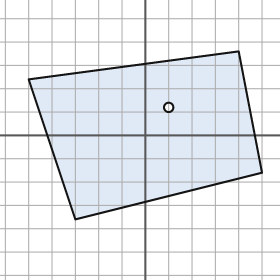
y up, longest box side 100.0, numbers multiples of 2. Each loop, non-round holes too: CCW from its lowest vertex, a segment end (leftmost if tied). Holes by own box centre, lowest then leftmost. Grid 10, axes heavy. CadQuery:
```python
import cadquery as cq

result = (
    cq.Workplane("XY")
    .moveTo(-30.0, -36.0)
    .lineTo(50.0, -16.0)
    .lineTo(40.0, 36.0)
    .lineTo(-50.0, 24.0)
    .close()
    .moveTo(10.0, 12.0)
    .circle(2.0)
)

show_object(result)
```